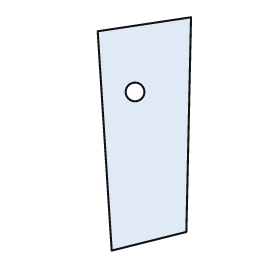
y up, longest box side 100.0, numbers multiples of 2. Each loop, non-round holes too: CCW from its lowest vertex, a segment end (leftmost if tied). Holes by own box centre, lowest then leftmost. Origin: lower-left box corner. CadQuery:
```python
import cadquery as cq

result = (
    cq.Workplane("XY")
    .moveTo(6.0, 0.0)
    .lineTo(38.0, 8.0)
    .lineTo(40.0, 100.0)
    .lineTo(0.0, 94.0)
    .close()
    .moveTo(16.0, 68.0)
    .circle(4.0)
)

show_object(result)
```